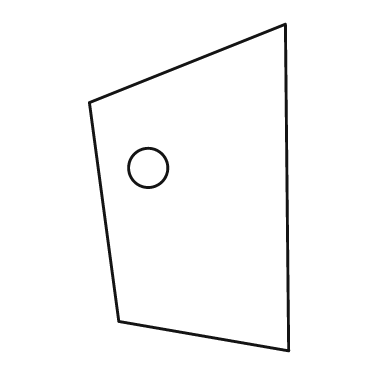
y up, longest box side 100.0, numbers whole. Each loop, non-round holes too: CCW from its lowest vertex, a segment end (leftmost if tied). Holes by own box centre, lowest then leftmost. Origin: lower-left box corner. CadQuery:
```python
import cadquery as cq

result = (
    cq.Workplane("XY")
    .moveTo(61.0, 0.0)
    .lineTo(60.0, 100.0)
    .lineTo(0.0, 76.0)
    .lineTo(9.0, 9.0)
    .close()
    .moveTo(18.0, 56.0)
    .circle(6.0)
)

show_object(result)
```